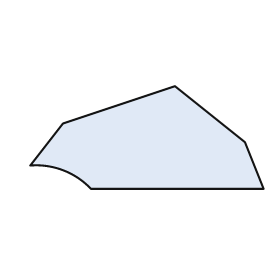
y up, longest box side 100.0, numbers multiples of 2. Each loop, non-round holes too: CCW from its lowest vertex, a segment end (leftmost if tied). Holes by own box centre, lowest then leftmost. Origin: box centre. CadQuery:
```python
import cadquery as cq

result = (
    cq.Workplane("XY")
    .moveTo(-24.0, -22.0)
    .lineTo(50.0, -22.0)
    .lineTo(42.0, -2.0)
    .lineTo(12.0, 22.0)
    .lineTo(-36.0, 6.0)
    .lineTo(-50.0, -12.0)
    .threePointArc((-36.0, -14.0), (-24.0, -22.0))
    .close()
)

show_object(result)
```